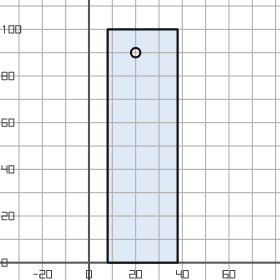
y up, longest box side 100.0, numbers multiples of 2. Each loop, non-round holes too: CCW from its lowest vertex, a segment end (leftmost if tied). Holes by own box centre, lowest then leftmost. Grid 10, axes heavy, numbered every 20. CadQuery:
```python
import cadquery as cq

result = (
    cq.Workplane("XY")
    .moveTo(8.0, 0.0)
    .lineTo(38.0, 0.0)
    .lineTo(38.0, 100.0)
    .lineTo(8.0, 100.0)
    .close()
    .moveTo(20.0, 90.0)
    .circle(2.0)
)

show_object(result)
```